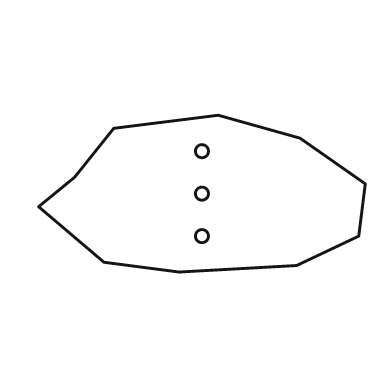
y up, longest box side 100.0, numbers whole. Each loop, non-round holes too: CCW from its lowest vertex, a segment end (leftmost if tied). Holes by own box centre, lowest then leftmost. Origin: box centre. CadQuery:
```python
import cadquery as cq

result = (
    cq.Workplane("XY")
    .moveTo(-7.0, -24.0)
    .lineTo(29.0, -22.0)
    .lineTo(48.0, -13.0)
    .lineTo(50.0, 3.0)
    .lineTo(30.0, 17.0)
    .lineTo(5.0, 24.0)
    .lineTo(-27.0, 20.0)
    .lineTo(-39.0, 5.0)
    .lineTo(-50.0, -4.0)
    .lineTo(-30.0, -21.0)
    .close()
    .moveTo(0.0, -13.0)
    .circle(2.0)
    .moveTo(0.0, 0.0)
    .circle(2.0)
    .moveTo(0.0, 13.0)
    .circle(2.0)
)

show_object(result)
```